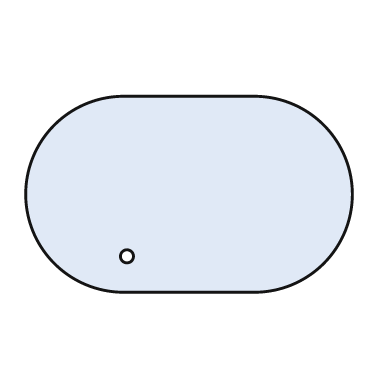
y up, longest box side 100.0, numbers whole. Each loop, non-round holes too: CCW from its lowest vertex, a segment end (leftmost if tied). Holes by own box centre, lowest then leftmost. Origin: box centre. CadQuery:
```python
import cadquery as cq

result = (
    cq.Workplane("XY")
    .moveTo(-20.0, -30.0)
    .lineTo(20.0, -30.0)
    .threePointArc((50.0, 0.0), (20.0, 30.0))
    .lineTo(-20.0, 30.0)
    .threePointArc((-50.0, 0.0), (-20.0, -30.0))
    .close()
    .moveTo(-19.0, -19.0)
    .circle(2.0)
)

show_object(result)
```